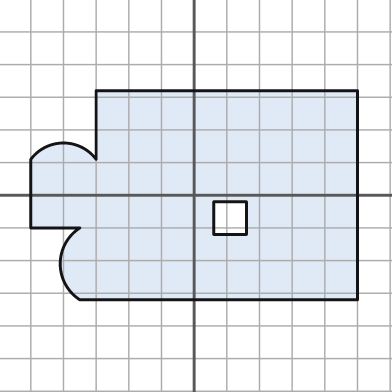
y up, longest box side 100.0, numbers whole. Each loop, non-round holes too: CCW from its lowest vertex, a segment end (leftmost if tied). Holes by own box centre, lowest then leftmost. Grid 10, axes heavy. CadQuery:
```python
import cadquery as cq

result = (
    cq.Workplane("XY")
    .moveTo(-35.0, -32.0)
    .lineTo(50.0, -32.0)
    .lineTo(50.0, 32.0)
    .lineTo(-30.0, 32.0)
    .lineTo(-30.0, 11.0)
    .threePointArc((-40.0, 16.0), (-50.0, 11.0))
    .lineTo(-50.0, -10.0)
    .lineTo(-35.0, -10.0)
    .threePointArc((-41.0, -21.0), (-35.0, -32.0))
    .close()
    .moveTo(6.0, -12.0)
    .lineTo(16.0, -12.0)
    .lineTo(16.0, -2.0)
    .lineTo(6.0, -2.0)
    .close()
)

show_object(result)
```